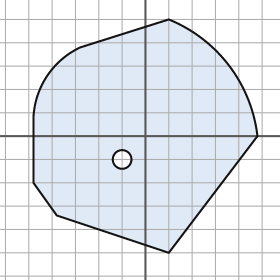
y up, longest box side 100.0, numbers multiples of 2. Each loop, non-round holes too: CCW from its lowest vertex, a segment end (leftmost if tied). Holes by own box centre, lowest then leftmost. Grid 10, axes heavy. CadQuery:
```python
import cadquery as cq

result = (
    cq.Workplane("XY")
    .moveTo(10.0, -50.0)
    .lineTo(48.0, 0.0)
    .threePointArc((36.0, 30.0), (10.0, 50.0))
    .lineTo(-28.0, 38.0)
    .threePointArc((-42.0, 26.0), (-48.0, 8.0))
    .lineTo(-48.0, -20.0)
    .lineTo(-38.0, -34.0)
    .close()
    .moveTo(-10.0, -10.0)
    .circle(4.0)
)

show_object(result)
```